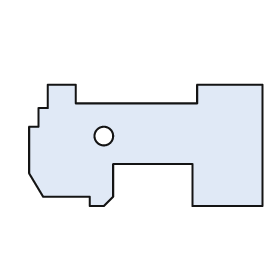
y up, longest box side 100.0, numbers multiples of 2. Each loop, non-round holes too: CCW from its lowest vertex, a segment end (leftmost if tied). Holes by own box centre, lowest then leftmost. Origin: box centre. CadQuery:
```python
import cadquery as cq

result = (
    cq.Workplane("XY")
    .moveTo(-24.0, -26.0)
    .lineTo(-18.0, -26.0)
    .lineTo(-14.0, -22.0)
    .lineTo(-14.0, -8.0)
    .lineTo(20.0, -8.0)
    .lineTo(20.0, -26.0)
    .lineTo(50.0, -26.0)
    .lineTo(50.0, 26.0)
    .lineTo(22.0, 26.0)
    .lineTo(22.0, 18.0)
    .lineTo(-30.0, 18.0)
    .lineTo(-30.0, 26.0)
    .lineTo(-42.0, 26.0)
    .lineTo(-42.0, 16.0)
    .lineTo(-46.0, 16.0)
    .lineTo(-46.0, 8.0)
    .lineTo(-50.0, 8.0)
    .lineTo(-50.0, -12.0)
    .lineTo(-44.0, -22.0)
    .lineTo(-24.0, -22.0)
    .close()
    .moveTo(-18.0, 4.0)
    .circle(4.0)
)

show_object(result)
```